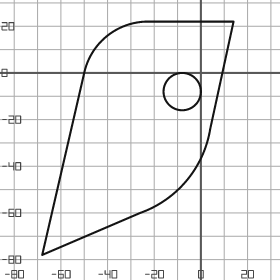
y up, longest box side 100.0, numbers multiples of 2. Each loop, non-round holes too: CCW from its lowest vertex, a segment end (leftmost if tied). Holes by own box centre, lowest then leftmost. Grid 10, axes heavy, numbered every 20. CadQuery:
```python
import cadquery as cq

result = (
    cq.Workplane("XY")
    .moveTo(-68.0, -78.0)
    .lineTo(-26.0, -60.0)
    .threePointArc((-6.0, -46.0), (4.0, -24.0))
    .lineTo(14.0, 22.0)
    .lineTo(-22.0, 22.0)
    .threePointArc((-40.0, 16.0), (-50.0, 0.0))
    .close()
    .moveTo(-8.0, -8.0)
    .circle(8.0)
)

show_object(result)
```